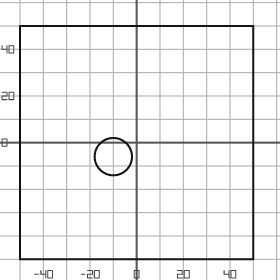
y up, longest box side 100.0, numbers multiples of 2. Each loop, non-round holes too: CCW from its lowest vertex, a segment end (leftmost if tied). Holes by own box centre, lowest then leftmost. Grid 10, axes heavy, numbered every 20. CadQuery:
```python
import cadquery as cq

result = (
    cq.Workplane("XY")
    .moveTo(-50.0, -50.0)
    .lineTo(50.0, -50.0)
    .lineTo(50.0, 50.0)
    .lineTo(-50.0, 50.0)
    .close()
    .moveTo(-10.0, -6.0)
    .circle(8.0)
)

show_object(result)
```